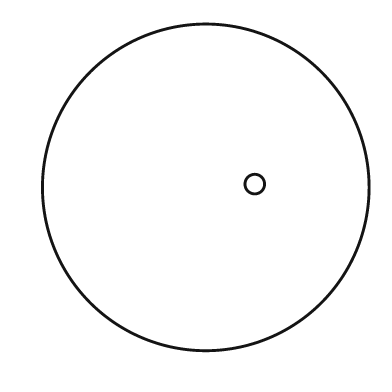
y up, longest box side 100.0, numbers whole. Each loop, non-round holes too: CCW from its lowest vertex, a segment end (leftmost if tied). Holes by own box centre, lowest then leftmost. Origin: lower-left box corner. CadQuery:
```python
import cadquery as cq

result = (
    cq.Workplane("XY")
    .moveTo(50.0, 50.0)
    .circle(50.0)
    .moveTo(65.0, 51.0)
    .circle(3.0)
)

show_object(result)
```